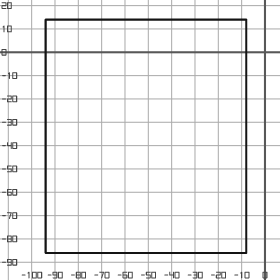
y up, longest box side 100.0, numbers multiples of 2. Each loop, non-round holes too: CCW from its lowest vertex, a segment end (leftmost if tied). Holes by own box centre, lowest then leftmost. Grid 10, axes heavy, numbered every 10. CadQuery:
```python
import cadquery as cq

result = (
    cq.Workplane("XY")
    .moveTo(-94.0, -86.0)
    .lineTo(-8.0, -86.0)
    .lineTo(-8.0, 14.0)
    .lineTo(-94.0, 14.0)
    .close()
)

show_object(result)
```